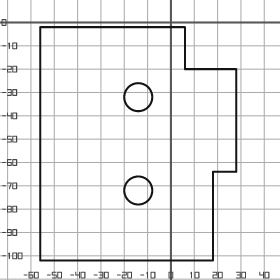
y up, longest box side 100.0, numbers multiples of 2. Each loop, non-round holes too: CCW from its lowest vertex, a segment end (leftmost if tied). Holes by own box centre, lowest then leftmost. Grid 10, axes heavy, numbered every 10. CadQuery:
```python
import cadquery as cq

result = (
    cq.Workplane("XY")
    .moveTo(-56.0, -102.0)
    .lineTo(18.0, -102.0)
    .lineTo(18.0, -64.0)
    .lineTo(28.0, -64.0)
    .lineTo(28.0, -20.0)
    .lineTo(6.0, -20.0)
    .lineTo(6.0, -2.0)
    .lineTo(-56.0, -2.0)
    .close()
    .moveTo(-14.0, -72.0)
    .circle(6.0)
    .moveTo(-14.0, -32.0)
    .circle(6.0)
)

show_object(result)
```